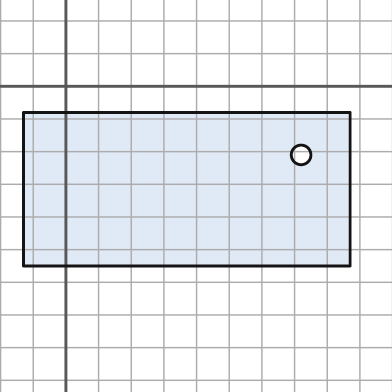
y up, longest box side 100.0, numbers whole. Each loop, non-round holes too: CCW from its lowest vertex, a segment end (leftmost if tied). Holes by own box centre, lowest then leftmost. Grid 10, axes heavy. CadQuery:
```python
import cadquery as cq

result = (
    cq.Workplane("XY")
    .moveTo(-13.0, -55.0)
    .lineTo(87.0, -55.0)
    .lineTo(87.0, -8.0)
    .lineTo(-13.0, -8.0)
    .close()
    .moveTo(72.0, -21.0)
    .circle(3.0)
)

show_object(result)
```